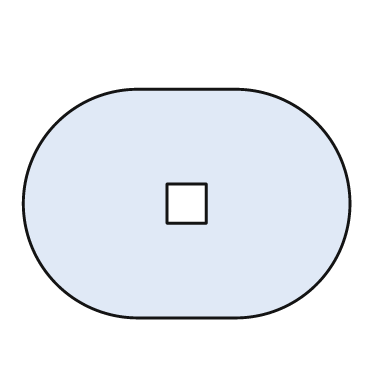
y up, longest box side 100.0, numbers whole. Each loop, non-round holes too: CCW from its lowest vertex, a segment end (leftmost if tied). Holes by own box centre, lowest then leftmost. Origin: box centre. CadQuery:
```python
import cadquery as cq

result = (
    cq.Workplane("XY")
    .moveTo(-15.0, -35.0)
    .lineTo(15.0, -35.0)
    .threePointArc((50.0, 0.0), (15.0, 35.0))
    .lineTo(-15.0, 35.0)
    .threePointArc((-50.0, 0.0), (-15.0, -35.0))
    .close()
    .moveTo(-6.0, -6.0)
    .lineTo(6.0, -6.0)
    .lineTo(6.0, 6.0)
    .lineTo(-6.0, 6.0)
    .close()
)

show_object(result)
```